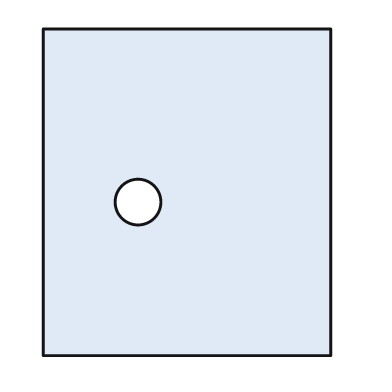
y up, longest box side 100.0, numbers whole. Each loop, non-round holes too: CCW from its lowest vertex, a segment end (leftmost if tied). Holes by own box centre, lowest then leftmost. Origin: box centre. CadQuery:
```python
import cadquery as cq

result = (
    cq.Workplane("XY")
    .moveTo(-44.0, -50.0)
    .lineTo(44.0, -50.0)
    .lineTo(44.0, 50.0)
    .lineTo(-44.0, 50.0)
    .close()
    .moveTo(-15.0, -3.0)
    .circle(7.0)
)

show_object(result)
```